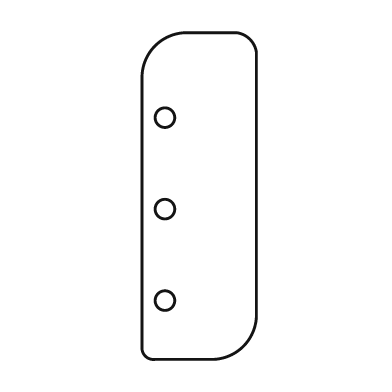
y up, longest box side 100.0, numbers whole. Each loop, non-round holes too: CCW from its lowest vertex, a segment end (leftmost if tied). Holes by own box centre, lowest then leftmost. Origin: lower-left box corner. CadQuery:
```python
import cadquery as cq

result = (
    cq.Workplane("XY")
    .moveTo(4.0, 0.0)
    .lineTo(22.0, 0.0)
    .threePointArc((31.0, 4.0), (35.0, 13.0))
    .lineTo(35.0, 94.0)
    .threePointArc((33.0, 98.0), (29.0, 100.0))
    .lineTo(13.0, 100.0)
    .threePointArc((4.0, 96.0), (0.0, 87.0))
    .lineTo(0.0, 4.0)
    .threePointArc((1.0, 1.0), (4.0, 0.0))
    .close()
    .moveTo(7.0, 18.0)
    .circle(3.0)
    .moveTo(7.0, 46.0)
    .circle(3.0)
    .moveTo(7.0, 74.0)
    .circle(3.0)
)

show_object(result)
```